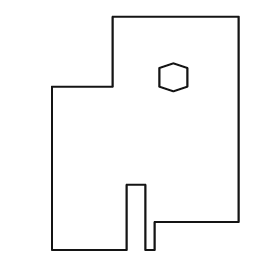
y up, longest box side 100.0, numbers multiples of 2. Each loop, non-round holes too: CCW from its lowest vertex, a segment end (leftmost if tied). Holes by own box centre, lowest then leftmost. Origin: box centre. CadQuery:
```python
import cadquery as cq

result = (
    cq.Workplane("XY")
    .moveTo(-40.0, -50.0)
    .lineTo(-8.0, -50.0)
    .lineTo(-8.0, -22.0)
    .lineTo(0.0, -22.0)
    .lineTo(0.0, -50.0)
    .lineTo(4.0, -50.0)
    .lineTo(4.0, -38.0)
    .lineTo(40.0, -38.0)
    .lineTo(40.0, 50.0)
    .lineTo(-14.0, 50.0)
    .lineTo(-14.0, 20.0)
    .lineTo(-40.0, 20.0)
    .close()
    .moveTo(12.0, 18.0)
    .lineTo(18.0, 20.0)
    .lineTo(18.0, 28.0)
    .lineTo(12.0, 30.0)
    .lineTo(6.0, 28.0)
    .lineTo(6.0, 20.0)
    .close()
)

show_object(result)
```